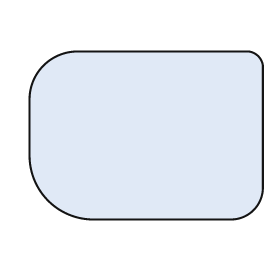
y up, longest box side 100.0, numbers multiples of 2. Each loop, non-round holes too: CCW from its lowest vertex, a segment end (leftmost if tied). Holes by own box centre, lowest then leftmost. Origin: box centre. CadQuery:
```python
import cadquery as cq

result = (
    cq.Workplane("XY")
    .moveTo(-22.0, -36.0)
    .lineTo(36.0, -36.0)
    .threePointArc((46.0, -32.0), (50.0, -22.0))
    .lineTo(50.0, 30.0)
    .threePointArc((48.0, 34.0), (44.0, 36.0))
    .lineTo(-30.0, 36.0)
    .threePointArc((-44.0, 30.0), (-50.0, 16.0))
    .lineTo(-50.0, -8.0)
    .threePointArc((-42.0, -28.0), (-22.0, -36.0))
    .close()
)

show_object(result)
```